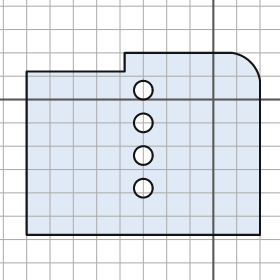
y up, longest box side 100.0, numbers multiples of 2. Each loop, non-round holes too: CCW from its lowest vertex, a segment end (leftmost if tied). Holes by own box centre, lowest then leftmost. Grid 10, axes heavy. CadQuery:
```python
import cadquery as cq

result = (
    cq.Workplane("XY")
    .moveTo(-80.0, -58.0)
    .lineTo(20.0, -58.0)
    .lineTo(20.0, 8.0)
    .threePointArc((16.0, 16.0), (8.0, 20.0))
    .lineTo(-38.0, 20.0)
    .lineTo(-38.0, 12.0)
    .lineTo(-80.0, 12.0)
    .close()
    .moveTo(-30.0, -38.0)
    .circle(4.0)
    .moveTo(-30.0, -24.0)
    .circle(4.0)
    .moveTo(-30.0, -10.0)
    .circle(4.0)
    .moveTo(-30.0, 4.0)
    .circle(4.0)
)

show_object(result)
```